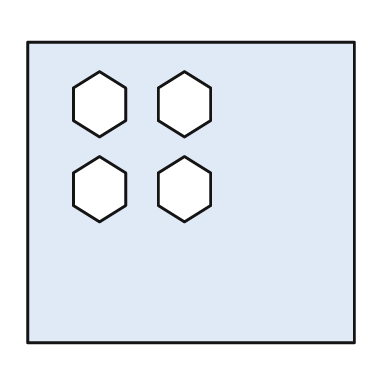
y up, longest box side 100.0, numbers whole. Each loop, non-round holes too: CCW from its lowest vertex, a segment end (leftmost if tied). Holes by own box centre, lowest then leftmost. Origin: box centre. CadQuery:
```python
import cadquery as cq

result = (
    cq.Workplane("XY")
    .moveTo(-50.0, -46.0)
    .lineTo(50.0, -46.0)
    .lineTo(50.0, 46.0)
    .lineTo(-50.0, 46.0)
    .close()
    .moveTo(-28.0, -9.0)
    .lineTo(-20.0, -4.0)
    .lineTo(-20.0, 6.0)
    .lineTo(-28.0, 11.0)
    .lineTo(-36.0, 6.0)
    .lineTo(-36.0, -4.0)
    .close()
    .moveTo(-2.0, -9.0)
    .lineTo(6.0, -4.0)
    .lineTo(6.0, 6.0)
    .lineTo(-2.0, 11.0)
    .lineTo(-10.0, 6.0)
    .lineTo(-10.0, -4.0)
    .close()
    .moveTo(-28.0, 17.0)
    .lineTo(-20.0, 22.0)
    .lineTo(-20.0, 32.0)
    .lineTo(-28.0, 37.0)
    .lineTo(-36.0, 32.0)
    .lineTo(-36.0, 22.0)
    .close()
    .moveTo(-2.0, 17.0)
    .lineTo(6.0, 22.0)
    .lineTo(6.0, 32.0)
    .lineTo(-2.0, 37.0)
    .lineTo(-10.0, 32.0)
    .lineTo(-10.0, 22.0)
    .close()
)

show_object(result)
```